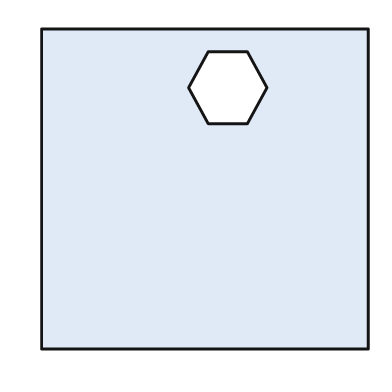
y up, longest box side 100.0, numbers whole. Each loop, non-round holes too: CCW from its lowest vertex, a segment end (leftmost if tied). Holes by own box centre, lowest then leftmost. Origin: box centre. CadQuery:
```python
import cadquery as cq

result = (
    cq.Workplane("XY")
    .moveTo(-50.0, -49.0)
    .lineTo(50.0, -49.0)
    .lineTo(50.0, 49.0)
    .lineTo(-50.0, 49.0)
    .close()
    .moveTo(1.0, 20.0)
    .lineTo(13.0, 20.0)
    .lineTo(19.0, 31.0)
    .lineTo(13.0, 42.0)
    .lineTo(1.0, 42.0)
    .lineTo(-5.0, 31.0)
    .close()
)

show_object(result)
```